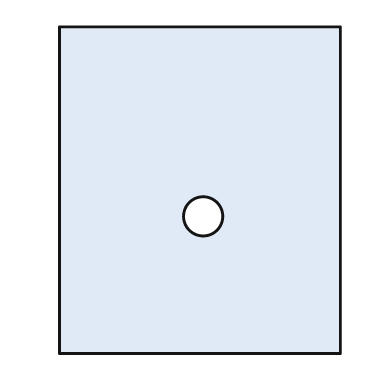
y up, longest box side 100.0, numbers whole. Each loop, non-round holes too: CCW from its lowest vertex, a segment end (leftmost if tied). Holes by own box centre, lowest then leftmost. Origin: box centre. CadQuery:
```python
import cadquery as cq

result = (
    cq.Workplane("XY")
    .moveTo(-43.0, -50.0)
    .lineTo(43.0, -50.0)
    .lineTo(43.0, 50.0)
    .lineTo(-43.0, 50.0)
    .close()
    .moveTo(1.0, -8.0)
    .circle(6.0)
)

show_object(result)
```